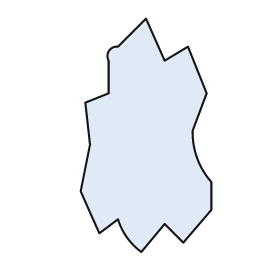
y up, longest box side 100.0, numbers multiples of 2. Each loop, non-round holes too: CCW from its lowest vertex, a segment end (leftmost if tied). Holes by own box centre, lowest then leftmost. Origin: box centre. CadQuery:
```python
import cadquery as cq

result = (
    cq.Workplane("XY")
    .moveTo(-2.0, -50.0)
    .lineTo(8.0, -38.0)
    .lineTo(16.0, -46.0)
    .lineTo(28.0, -32.0)
    .lineTo(28.0, -20.0)
    .threePointArc((22.0, -10.0), (20.0, 2.0))
    .lineTo(26.0, 18.0)
    .lineTo(18.0, 38.0)
    .lineTo(8.0, 32.0)
    .lineTo(0.0, 50.0)
    .lineTo(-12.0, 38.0)
    .threePointArc((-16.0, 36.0), (-16.0, 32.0))
    .lineTo(-16.0, 18.0)
    .lineTo(-26.0, 14.0)
    .lineTo(-24.0, -4.0)
    .lineTo(-28.0, -24.0)
    .lineTo(-20.0, -42.0)
    .lineTo(-12.0, -36.0)
    .threePointArc((-8.0, -44.0), (-2.0, -50.0))
    .close()
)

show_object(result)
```